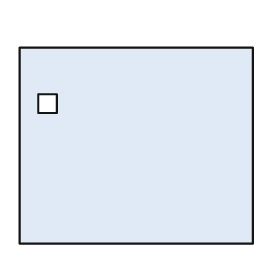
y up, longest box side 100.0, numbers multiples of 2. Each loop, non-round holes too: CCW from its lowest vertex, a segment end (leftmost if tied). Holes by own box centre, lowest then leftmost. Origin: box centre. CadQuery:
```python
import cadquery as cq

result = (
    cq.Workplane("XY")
    .moveTo(-50.0, -42.0)
    .lineTo(50.0, -42.0)
    .lineTo(50.0, 42.0)
    .lineTo(-50.0, 42.0)
    .close()
    .moveTo(-42.0, 14.0)
    .lineTo(-34.0, 14.0)
    .lineTo(-34.0, 22.0)
    .lineTo(-42.0, 22.0)
    .close()
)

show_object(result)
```